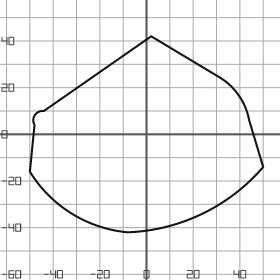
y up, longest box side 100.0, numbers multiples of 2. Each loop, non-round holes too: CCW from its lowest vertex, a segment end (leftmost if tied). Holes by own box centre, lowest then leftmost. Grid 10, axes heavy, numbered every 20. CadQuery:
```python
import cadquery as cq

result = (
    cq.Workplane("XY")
    .moveTo(-8.0, -42.0)
    .threePointArc((24.0, -34.0), (50.0, -14.0))
    .lineTo(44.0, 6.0)
    .threePointArc((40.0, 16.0), (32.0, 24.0))
    .lineTo(2.0, 42.0)
    .lineTo(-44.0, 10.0)
    .threePointArc((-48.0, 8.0), (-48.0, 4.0))
    .lineTo(-50.0, -16.0)
    .threePointArc((-32.0, -34.0), (-8.0, -42.0))
    .close()
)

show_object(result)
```